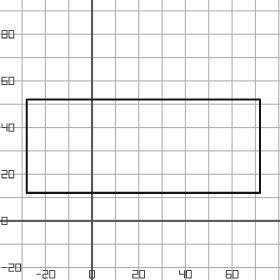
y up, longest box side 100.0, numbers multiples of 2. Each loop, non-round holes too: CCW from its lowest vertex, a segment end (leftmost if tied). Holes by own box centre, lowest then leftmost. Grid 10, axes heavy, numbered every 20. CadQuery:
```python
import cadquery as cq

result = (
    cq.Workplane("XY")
    .moveTo(-28.0, 12.0)
    .lineTo(72.0, 12.0)
    .lineTo(72.0, 52.0)
    .lineTo(-28.0, 52.0)
    .close()
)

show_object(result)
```